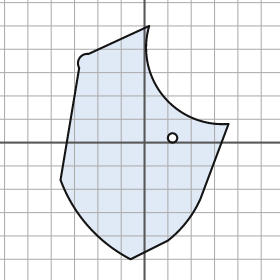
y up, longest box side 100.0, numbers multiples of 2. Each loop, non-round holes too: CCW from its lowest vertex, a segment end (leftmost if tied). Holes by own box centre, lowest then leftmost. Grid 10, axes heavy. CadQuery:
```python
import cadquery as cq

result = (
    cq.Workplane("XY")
    .moveTo(-6.0, -50.0)
    .lineTo(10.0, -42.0)
    .threePointArc((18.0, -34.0), (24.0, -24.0))
    .lineTo(36.0, 8.0)
    .threePointArc((8.0, 20.0), (2.0, 50.0))
    .lineTo(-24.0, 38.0)
    .threePointArc((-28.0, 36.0), (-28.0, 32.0))
    .lineTo(-36.0, -16.0)
    .threePointArc((-24.0, -36.0), (-6.0, -50.0))
    .close()
    .moveTo(12.0, 2.0)
    .circle(2.0)
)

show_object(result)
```